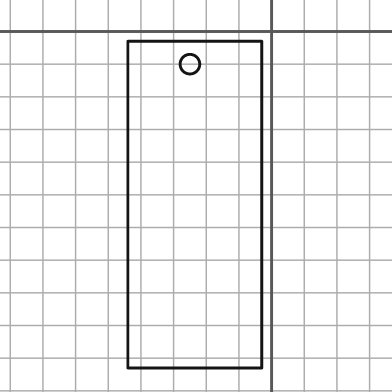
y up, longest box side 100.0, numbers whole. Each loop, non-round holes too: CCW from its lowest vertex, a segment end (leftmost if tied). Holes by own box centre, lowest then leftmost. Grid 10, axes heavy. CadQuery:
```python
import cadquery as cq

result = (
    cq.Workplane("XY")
    .moveTo(-44.0, -103.0)
    .lineTo(-3.0, -103.0)
    .lineTo(-3.0, -3.0)
    .lineTo(-44.0, -3.0)
    .close()
    .moveTo(-25.0, -10.0)
    .circle(3.0)
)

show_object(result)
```